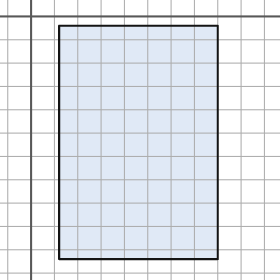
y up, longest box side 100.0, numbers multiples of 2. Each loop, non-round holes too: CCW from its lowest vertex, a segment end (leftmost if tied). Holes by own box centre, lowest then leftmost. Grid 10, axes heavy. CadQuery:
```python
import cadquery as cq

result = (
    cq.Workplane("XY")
    .moveTo(12.0, -104.0)
    .lineTo(80.0, -104.0)
    .lineTo(80.0, -4.0)
    .lineTo(12.0, -4.0)
    .close()
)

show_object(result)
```